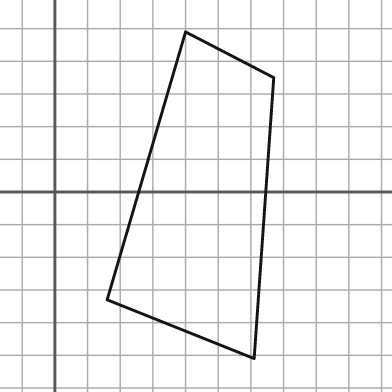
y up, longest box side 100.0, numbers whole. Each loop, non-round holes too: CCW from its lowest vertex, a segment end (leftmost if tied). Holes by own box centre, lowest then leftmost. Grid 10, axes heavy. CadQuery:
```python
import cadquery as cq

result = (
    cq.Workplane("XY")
    .moveTo(61.0, -51.0)
    .lineTo(67.0, 35.0)
    .lineTo(40.0, 49.0)
    .lineTo(16.0, -33.0)
    .close()
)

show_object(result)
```